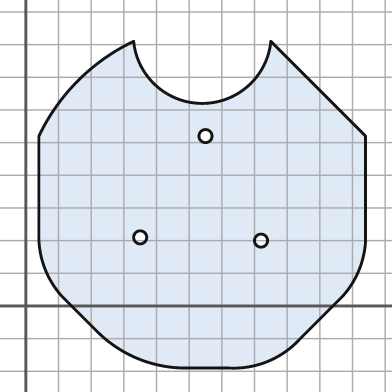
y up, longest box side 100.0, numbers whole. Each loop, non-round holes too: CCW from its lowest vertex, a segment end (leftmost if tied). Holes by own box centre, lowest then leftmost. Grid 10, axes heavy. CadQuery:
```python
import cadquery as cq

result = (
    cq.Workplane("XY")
    .moveTo(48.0, -19.0)
    .lineTo(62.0, -19.0)
    .threePointArc((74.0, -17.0), (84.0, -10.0))
    .lineTo(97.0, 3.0)
    .threePointArc((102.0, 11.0), (104.0, 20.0))
    .lineTo(104.0, 52.0)
    .lineTo(75.0, 81.0)
    .threePointArc((54.0, 62.0), (33.0, 81.0))
    .threePointArc((16.0, 69.0), (4.0, 52.0))
    .lineTo(4.0, 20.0)
    .threePointArc((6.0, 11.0), (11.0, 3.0))
    .lineTo(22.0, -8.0)
    .threePointArc((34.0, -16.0), (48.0, -19.0))
    .close()
    .moveTo(72.0, 20.0)
    .circle(2.0)
    .moveTo(35.0, 21.0)
    .circle(2.0)
    .moveTo(55.0, 52.0)
    .circle(2.0)
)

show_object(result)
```